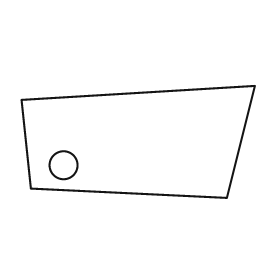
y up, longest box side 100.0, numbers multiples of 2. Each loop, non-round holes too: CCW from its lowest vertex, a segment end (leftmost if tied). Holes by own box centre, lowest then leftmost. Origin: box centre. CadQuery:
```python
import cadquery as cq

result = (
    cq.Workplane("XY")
    .moveTo(38.0, -24.0)
    .lineTo(50.0, 24.0)
    .lineTo(-50.0, 18.0)
    .lineTo(-46.0, -20.0)
    .close()
    .moveTo(-32.0, -10.0)
    .circle(6.0)
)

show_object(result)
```